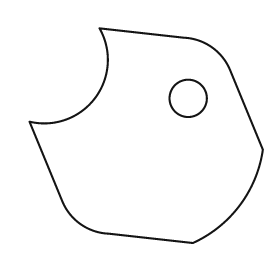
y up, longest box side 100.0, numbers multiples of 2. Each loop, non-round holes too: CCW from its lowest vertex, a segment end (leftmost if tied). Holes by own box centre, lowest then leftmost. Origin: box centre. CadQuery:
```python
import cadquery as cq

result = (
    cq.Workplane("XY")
    .moveTo(20.0, -46.0)
    .threePointArc((40.0, -30.0), (50.0, -6.0))
    .lineTo(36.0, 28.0)
    .threePointArc((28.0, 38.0), (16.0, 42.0))
    .lineTo(-20.0, 46.0)
    .threePointArc((-22.0, 16.0), (-50.0, 6.0))
    .lineTo(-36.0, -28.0)
    .threePointArc((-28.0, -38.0), (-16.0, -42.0))
    .close()
    .moveTo(18.0, 16.0)
    .circle(8.0)
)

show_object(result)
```